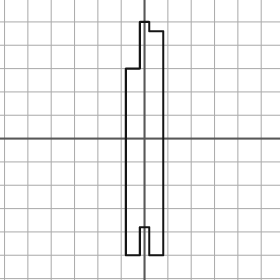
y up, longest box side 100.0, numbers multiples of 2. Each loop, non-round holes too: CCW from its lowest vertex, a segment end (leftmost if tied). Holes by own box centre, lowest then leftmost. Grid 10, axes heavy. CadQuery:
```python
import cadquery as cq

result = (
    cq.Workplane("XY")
    .moveTo(-8.0, -50.0)
    .lineTo(-2.0, -50.0)
    .lineTo(-2.0, -38.0)
    .lineTo(2.0, -38.0)
    .lineTo(2.0, -50.0)
    .lineTo(8.0, -50.0)
    .lineTo(8.0, 46.0)
    .lineTo(2.0, 46.0)
    .lineTo(2.0, 50.0)
    .lineTo(-2.0, 50.0)
    .lineTo(-2.0, 30.0)
    .lineTo(-8.0, 30.0)
    .close()
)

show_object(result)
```